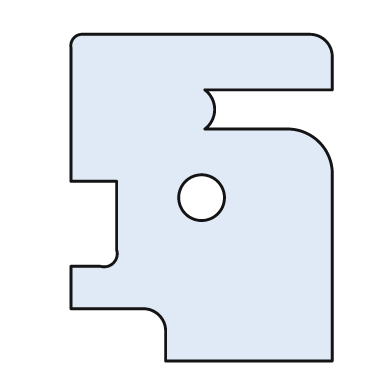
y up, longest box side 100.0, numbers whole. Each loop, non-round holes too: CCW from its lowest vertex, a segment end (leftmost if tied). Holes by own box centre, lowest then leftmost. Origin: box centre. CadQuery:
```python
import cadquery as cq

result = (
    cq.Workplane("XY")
    .moveTo(-11.0, -50.0)
    .lineTo(40.0, -50.0)
    .lineTo(40.0, 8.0)
    .threePointArc((36.0, 17.0), (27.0, 21.0))
    .lineTo(1.0, 21.0)
    .threePointArc((4.0, 27.0), (1.0, 33.0))
    .lineTo(40.0, 33.0)
    .lineTo(40.0, 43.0)
    .threePointArc((38.0, 48.0), (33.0, 50.0))
    .lineTo(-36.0, 50.0)
    .threePointArc((-39.0, 49.0), (-40.0, 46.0))
    .lineTo(-40.0, 5.0)
    .lineTo(-26.0, 5.0)
    .lineTo(-26.0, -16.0)
    .threePointArc((-27.0, -20.0), (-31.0, -21.0))
    .lineTo(-40.0, -21.0)
    .lineTo(-40.0, -34.0)
    .lineTo(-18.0, -34.0)
    .threePointArc((-13.0, -36.0), (-11.0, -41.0))
    .close()
    .moveTo(0.0, 0.0)
    .circle(7.0)
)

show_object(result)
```